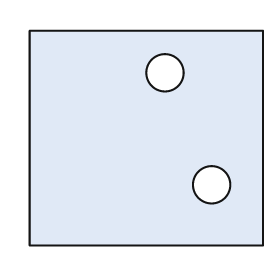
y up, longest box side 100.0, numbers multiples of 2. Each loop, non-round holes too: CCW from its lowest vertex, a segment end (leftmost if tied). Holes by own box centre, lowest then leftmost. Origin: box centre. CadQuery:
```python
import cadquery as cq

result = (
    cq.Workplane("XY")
    .moveTo(-50.0, -46.0)
    .lineTo(50.0, -46.0)
    .lineTo(50.0, 46.0)
    .lineTo(-50.0, 46.0)
    .close()
    .moveTo(28.0, -20.0)
    .circle(8.0)
    .moveTo(8.0, 28.0)
    .circle(8.0)
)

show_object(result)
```